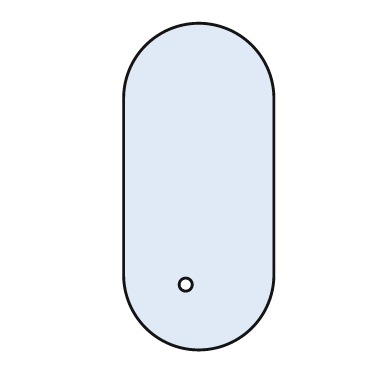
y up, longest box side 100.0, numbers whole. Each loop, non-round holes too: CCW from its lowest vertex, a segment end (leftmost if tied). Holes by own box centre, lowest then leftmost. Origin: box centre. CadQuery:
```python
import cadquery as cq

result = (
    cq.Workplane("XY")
    .moveTo(-23.0, -27.0)
    .threePointArc((0.0, -50.0), (23.0, -27.0))
    .lineTo(23.0, 27.0)
    .threePointArc((0.0, 50.0), (-23.0, 27.0))
    .close()
    .moveTo(-4.0, -30.0)
    .circle(2.0)
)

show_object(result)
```